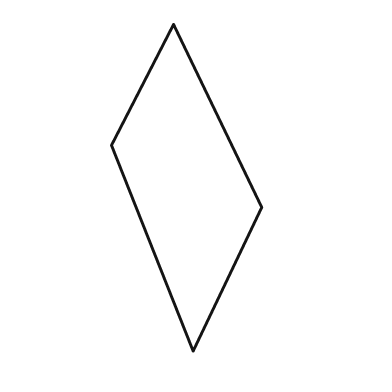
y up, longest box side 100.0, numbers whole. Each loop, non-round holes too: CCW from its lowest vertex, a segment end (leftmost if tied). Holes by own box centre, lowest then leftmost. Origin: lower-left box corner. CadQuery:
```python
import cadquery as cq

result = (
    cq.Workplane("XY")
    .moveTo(25.0, 0.0)
    .lineTo(46.0, 44.0)
    .lineTo(19.0, 100.0)
    .lineTo(0.0, 63.0)
    .close()
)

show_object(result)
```